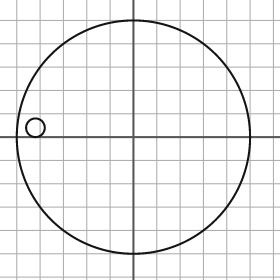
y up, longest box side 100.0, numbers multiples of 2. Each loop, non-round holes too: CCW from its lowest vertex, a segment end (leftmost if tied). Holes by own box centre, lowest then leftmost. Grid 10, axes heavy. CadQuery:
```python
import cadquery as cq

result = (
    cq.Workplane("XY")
    .moveTo(0.0, 0.0)
    .circle(50.0)
    .moveTo(-42.0, 4.0)
    .circle(4.0)
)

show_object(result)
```